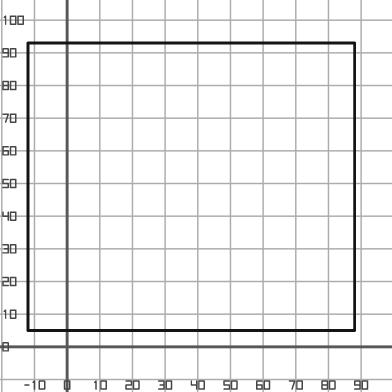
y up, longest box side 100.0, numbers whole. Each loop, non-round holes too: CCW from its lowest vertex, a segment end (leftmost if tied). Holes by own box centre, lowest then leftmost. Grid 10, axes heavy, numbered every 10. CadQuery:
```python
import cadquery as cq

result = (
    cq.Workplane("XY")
    .moveTo(-12.0, 5.0)
    .lineTo(88.0, 5.0)
    .lineTo(88.0, 93.0)
    .lineTo(-12.0, 93.0)
    .close()
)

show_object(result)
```